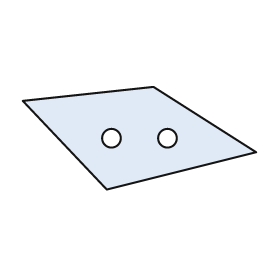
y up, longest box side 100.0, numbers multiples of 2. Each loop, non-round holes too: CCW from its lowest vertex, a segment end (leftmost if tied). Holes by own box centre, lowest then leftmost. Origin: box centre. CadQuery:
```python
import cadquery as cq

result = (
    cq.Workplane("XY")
    .moveTo(-14.0, -22.0)
    .lineTo(50.0, -6.0)
    .lineTo(6.0, 22.0)
    .lineTo(-50.0, 16.0)
    .close()
    .moveTo(-12.0, 0.0)
    .circle(4.0)
    .moveTo(12.0, 0.0)
    .circle(4.0)
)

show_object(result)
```